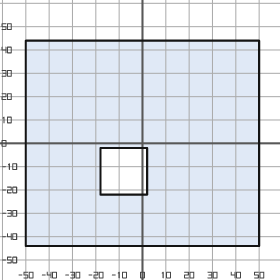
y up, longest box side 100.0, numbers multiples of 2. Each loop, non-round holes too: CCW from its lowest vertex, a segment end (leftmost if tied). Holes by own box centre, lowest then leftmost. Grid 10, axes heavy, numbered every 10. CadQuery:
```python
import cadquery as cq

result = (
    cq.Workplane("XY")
    .moveTo(-50.0, -44.0)
    .lineTo(50.0, -44.0)
    .lineTo(50.0, 44.0)
    .lineTo(-50.0, 44.0)
    .close()
    .moveTo(-18.0, -22.0)
    .lineTo(2.0, -22.0)
    .lineTo(2.0, -2.0)
    .lineTo(-18.0, -2.0)
    .close()
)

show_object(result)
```